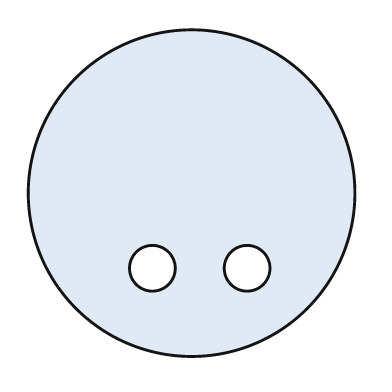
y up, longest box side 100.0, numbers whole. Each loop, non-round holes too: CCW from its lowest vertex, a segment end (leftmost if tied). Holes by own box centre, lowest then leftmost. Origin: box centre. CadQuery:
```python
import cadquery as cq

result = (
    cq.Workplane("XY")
    .moveTo(0.0, 0.0)
    .circle(50.0)
    .moveTo(-12.0, -23.0)
    .circle(7.0)
    .moveTo(17.0, -23.0)
    .circle(7.0)
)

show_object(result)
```